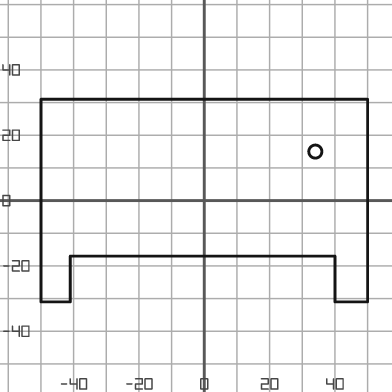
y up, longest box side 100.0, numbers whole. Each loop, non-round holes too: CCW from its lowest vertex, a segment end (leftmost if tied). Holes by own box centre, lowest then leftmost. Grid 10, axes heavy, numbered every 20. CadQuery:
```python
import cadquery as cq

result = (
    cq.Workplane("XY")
    .moveTo(-50.0, -31.0)
    .lineTo(-41.0, -31.0)
    .lineTo(-41.0, -17.0)
    .lineTo(40.0, -17.0)
    .lineTo(40.0, -31.0)
    .lineTo(50.0, -31.0)
    .lineTo(50.0, 31.0)
    .lineTo(-50.0, 31.0)
    .close()
    .moveTo(34.0, 15.0)
    .circle(2.0)
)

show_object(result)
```